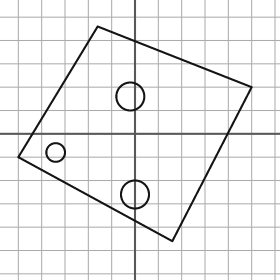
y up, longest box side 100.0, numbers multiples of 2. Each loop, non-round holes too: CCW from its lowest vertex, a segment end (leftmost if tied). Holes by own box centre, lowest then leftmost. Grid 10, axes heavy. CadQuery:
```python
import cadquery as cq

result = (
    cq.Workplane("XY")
    .moveTo(16.0, -46.0)
    .lineTo(50.0, 20.0)
    .lineTo(-16.0, 46.0)
    .lineTo(-50.0, -10.0)
    .close()
    .moveTo(0.0, -26.0)
    .circle(6.0)
    .moveTo(-34.0, -8.0)
    .circle(4.0)
    .moveTo(-2.0, 16.0)
    .circle(6.0)
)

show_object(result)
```